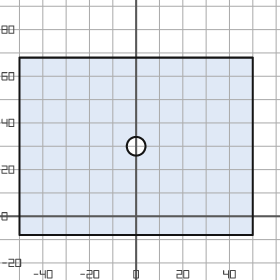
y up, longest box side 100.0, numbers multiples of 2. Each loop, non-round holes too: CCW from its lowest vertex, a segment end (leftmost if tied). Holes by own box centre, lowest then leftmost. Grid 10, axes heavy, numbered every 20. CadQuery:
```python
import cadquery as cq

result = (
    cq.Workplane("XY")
    .moveTo(-50.0, -8.0)
    .lineTo(50.0, -8.0)
    .lineTo(50.0, 68.0)
    .lineTo(-50.0, 68.0)
    .close()
    .moveTo(0.0, 30.0)
    .circle(4.0)
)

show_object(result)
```